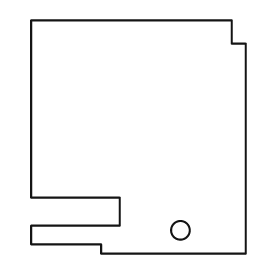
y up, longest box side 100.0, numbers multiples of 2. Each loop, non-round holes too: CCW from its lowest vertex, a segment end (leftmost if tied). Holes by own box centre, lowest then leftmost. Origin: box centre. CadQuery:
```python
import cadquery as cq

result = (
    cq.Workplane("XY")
    .moveTo(-16.0, -50.0)
    .lineTo(46.0, -50.0)
    .lineTo(46.0, 40.0)
    .lineTo(40.0, 40.0)
    .lineTo(40.0, 50.0)
    .lineTo(-46.0, 50.0)
    .lineTo(-46.0, -26.0)
    .lineTo(-8.0, -26.0)
    .lineTo(-8.0, -38.0)
    .lineTo(-46.0, -38.0)
    .lineTo(-46.0, -46.0)
    .lineTo(-16.0, -46.0)
    .close()
    .moveTo(18.0, -40.0)
    .circle(4.0)
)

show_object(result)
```